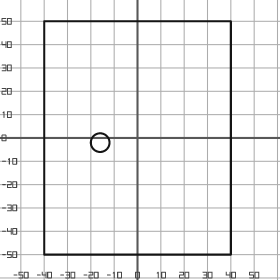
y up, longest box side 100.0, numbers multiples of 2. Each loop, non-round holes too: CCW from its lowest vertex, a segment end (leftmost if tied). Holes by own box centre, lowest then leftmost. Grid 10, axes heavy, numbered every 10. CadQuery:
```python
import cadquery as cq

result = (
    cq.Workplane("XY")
    .moveTo(-40.0, -50.0)
    .lineTo(40.0, -50.0)
    .lineTo(40.0, 50.0)
    .lineTo(-40.0, 50.0)
    .close()
    .moveTo(-16.0, -2.0)
    .circle(4.0)
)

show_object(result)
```